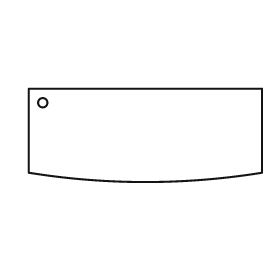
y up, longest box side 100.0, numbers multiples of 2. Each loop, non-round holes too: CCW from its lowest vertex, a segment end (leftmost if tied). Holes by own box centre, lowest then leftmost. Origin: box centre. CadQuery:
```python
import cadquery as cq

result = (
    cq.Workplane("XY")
    .moveTo(-50.0, -16.0)
    .threePointArc((0.0, -20.0), (50.0, -16.0))
    .lineTo(50.0, 20.0)
    .lineTo(-50.0, 20.0)
    .close()
    .moveTo(-44.0, 14.0)
    .circle(2.0)
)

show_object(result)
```